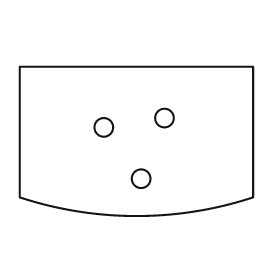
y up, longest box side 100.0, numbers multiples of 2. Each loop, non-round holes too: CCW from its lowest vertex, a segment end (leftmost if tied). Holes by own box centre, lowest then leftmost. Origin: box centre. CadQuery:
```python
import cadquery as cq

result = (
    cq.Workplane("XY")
    .moveTo(-50.0, -24.0)
    .threePointArc((0.0, -32.0), (50.0, -24.0))
    .lineTo(50.0, 32.0)
    .lineTo(-50.0, 32.0)
    .close()
    .moveTo(2.0, -16.0)
    .circle(4.0)
    .moveTo(-14.0, 6.0)
    .circle(4.0)
    .moveTo(12.0, 10.0)
    .circle(4.0)
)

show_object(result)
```